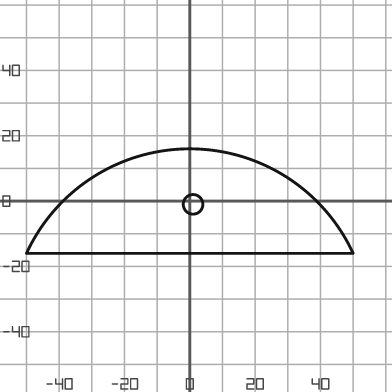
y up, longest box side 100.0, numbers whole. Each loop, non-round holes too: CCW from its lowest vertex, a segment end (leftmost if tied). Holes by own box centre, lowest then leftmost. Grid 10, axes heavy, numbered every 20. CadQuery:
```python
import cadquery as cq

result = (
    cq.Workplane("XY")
    .moveTo(-50.0, -16.0)
    .lineTo(50.0, -16.0)
    .threePointArc((0.0, 16.0), (-50.0, -16.0))
    .close()
    .moveTo(1.0, -1.0)
    .circle(3.0)
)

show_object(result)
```